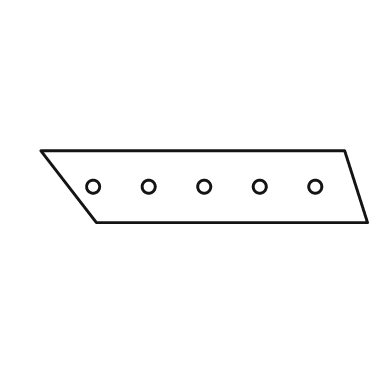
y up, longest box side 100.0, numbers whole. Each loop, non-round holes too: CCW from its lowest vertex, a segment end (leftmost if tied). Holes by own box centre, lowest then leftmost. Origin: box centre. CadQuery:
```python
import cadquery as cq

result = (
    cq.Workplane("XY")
    .moveTo(-33.0, -11.0)
    .lineTo(50.0, -11.0)
    .lineTo(43.0, 11.0)
    .lineTo(-50.0, 11.0)
    .close()
    .moveTo(-34.0, 0.0)
    .circle(2.0)
    .moveTo(-17.0, 0.0)
    .circle(2.0)
    .moveTo(0.0, 0.0)
    .circle(2.0)
    .moveTo(17.0, 0.0)
    .circle(2.0)
    .moveTo(34.0, 0.0)
    .circle(2.0)
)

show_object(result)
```